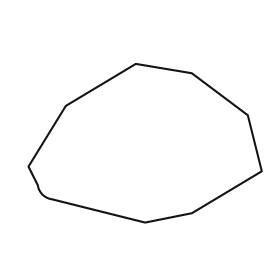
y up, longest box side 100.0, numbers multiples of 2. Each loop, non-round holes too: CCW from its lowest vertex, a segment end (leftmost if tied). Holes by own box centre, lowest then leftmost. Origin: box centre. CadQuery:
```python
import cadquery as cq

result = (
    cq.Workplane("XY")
    .moveTo(0.0, -34.0)
    .lineTo(20.0, -30.0)
    .lineTo(50.0, -12.0)
    .lineTo(44.0, 12.0)
    .lineTo(20.0, 30.0)
    .lineTo(-4.0, 34.0)
    .lineTo(-34.0, 16.0)
    .lineTo(-50.0, -10.0)
    .lineTo(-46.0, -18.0)
    .threePointArc((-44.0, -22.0), (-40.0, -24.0))
    .close()
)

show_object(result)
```